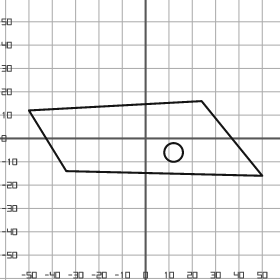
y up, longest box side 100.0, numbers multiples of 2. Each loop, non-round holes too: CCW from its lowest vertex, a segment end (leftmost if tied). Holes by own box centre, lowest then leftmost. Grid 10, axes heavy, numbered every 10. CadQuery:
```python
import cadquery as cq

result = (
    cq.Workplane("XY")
    .moveTo(50.0, -16.0)
    .lineTo(24.0, 16.0)
    .lineTo(-50.0, 12.0)
    .lineTo(-34.0, -14.0)
    .close()
    .moveTo(12.0, -6.0)
    .circle(4.0)
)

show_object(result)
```